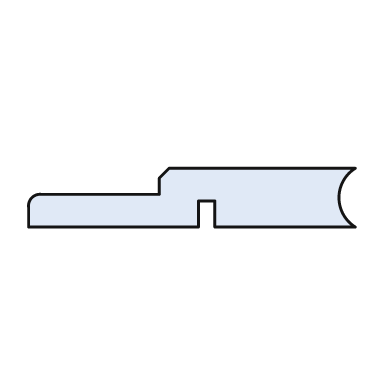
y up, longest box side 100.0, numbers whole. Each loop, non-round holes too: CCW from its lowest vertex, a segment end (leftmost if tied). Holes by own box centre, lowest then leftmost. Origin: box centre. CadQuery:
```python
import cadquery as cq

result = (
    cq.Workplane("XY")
    .moveTo(-50.0, -9.0)
    .lineTo(2.0, -9.0)
    .lineTo(2.0, -1.0)
    .lineTo(7.0, -1.0)
    .lineTo(7.0, -9.0)
    .lineTo(50.0, -9.0)
    .threePointArc((45.0, 0.0), (50.0, 9.0))
    .lineTo(-7.0, 9.0)
    .lineTo(-10.0, 6.0)
    .lineTo(-10.0, 1.0)
    .lineTo(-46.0, 1.0)
    .threePointArc((-49.0, 0.0), (-50.0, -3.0))
    .close()
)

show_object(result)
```